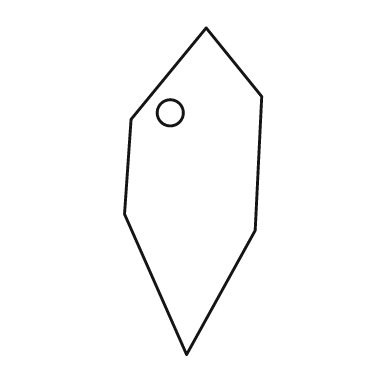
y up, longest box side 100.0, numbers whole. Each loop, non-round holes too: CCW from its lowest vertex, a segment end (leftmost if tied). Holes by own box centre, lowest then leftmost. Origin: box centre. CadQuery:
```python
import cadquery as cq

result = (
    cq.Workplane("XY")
    .moveTo(-2.0, -50.0)
    .lineTo(19.0, -12.0)
    .lineTo(21.0, 29.0)
    .lineTo(4.0, 50.0)
    .lineTo(-19.0, 22.0)
    .lineTo(-21.0, -7.0)
    .close()
    .moveTo(-7.0, 24.0)
    .circle(4.0)
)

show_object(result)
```